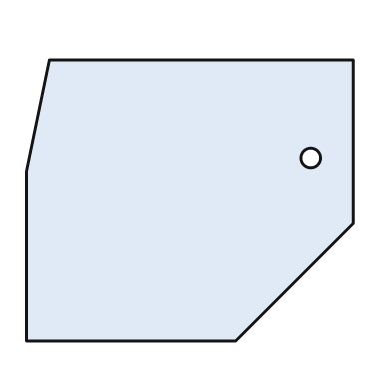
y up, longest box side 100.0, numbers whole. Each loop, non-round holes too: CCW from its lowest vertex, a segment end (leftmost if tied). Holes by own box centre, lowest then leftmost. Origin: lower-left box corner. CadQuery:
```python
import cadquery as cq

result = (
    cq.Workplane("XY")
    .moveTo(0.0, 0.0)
    .lineTo(64.0, 0.0)
    .lineTo(100.0, 36.0)
    .lineTo(100.0, 86.0)
    .lineTo(7.0, 86.0)
    .lineTo(0.0, 52.0)
    .close()
    .moveTo(87.0, 56.0)
    .circle(3.0)
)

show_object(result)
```